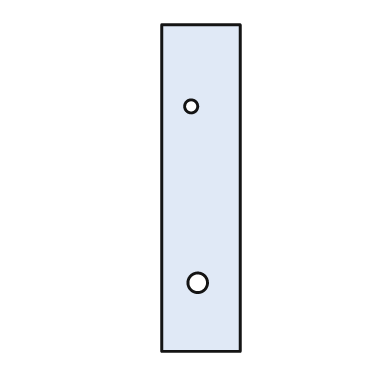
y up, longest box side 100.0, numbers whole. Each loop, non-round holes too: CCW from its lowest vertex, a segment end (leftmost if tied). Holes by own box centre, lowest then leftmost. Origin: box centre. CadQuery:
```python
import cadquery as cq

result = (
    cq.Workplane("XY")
    .moveTo(-12.0, -50.0)
    .lineTo(12.0, -50.0)
    .lineTo(12.0, 50.0)
    .lineTo(-12.0, 50.0)
    .close()
    .moveTo(-1.0, -29.0)
    .circle(3.0)
    .moveTo(-3.0, 25.0)
    .circle(2.0)
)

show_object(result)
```